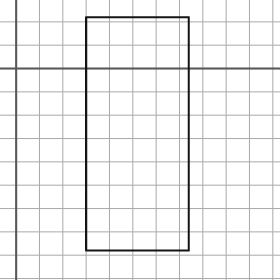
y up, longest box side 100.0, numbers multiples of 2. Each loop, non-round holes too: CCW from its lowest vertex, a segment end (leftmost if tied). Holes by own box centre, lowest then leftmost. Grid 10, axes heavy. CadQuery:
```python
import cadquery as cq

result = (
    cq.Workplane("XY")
    .moveTo(30.0, -78.0)
    .lineTo(74.0, -78.0)
    .lineTo(74.0, 22.0)
    .lineTo(30.0, 22.0)
    .close()
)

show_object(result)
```